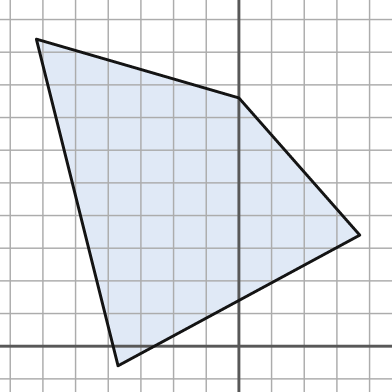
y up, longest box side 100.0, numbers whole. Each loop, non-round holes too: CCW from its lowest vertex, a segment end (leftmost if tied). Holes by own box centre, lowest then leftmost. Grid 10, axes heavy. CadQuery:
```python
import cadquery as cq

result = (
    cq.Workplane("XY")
    .moveTo(-37.0, -6.0)
    .lineTo(37.0, 34.0)
    .lineTo(0.0, 76.0)
    .lineTo(-62.0, 94.0)
    .close()
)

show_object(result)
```